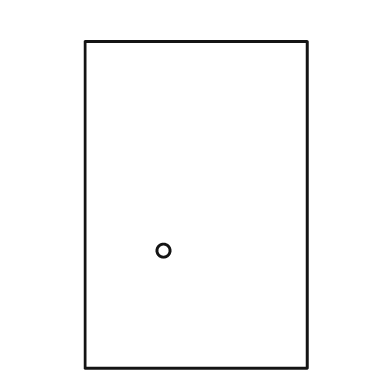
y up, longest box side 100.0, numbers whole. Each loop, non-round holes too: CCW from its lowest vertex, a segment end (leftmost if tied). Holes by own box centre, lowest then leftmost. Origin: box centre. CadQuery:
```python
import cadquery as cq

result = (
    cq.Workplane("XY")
    .moveTo(-34.0, -50.0)
    .lineTo(34.0, -50.0)
    .lineTo(34.0, 50.0)
    .lineTo(-34.0, 50.0)
    .close()
    .moveTo(-10.0, -14.0)
    .circle(2.0)
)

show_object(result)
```